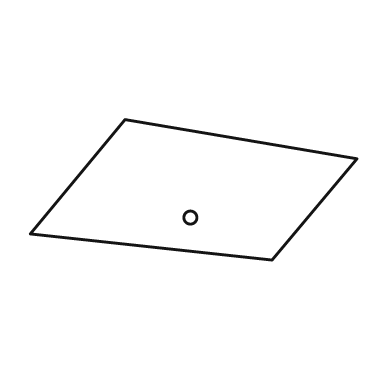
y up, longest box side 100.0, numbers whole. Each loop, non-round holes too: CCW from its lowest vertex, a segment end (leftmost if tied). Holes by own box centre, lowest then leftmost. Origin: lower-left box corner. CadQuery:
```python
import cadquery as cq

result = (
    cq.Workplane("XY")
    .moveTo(74.0, 0.0)
    .lineTo(100.0, 31.0)
    .lineTo(29.0, 43.0)
    .lineTo(0.0, 8.0)
    .close()
    .moveTo(49.0, 13.0)
    .circle(2.0)
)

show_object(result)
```